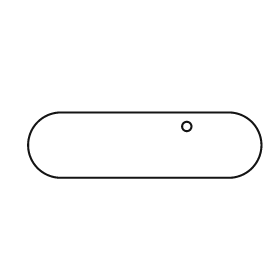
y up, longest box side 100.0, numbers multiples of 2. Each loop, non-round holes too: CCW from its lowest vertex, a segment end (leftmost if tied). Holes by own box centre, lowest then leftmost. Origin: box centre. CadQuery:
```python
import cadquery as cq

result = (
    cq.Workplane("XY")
    .moveTo(-36.0, -14.0)
    .lineTo(36.0, -14.0)
    .threePointArc((50.0, 0.0), (36.0, 14.0))
    .lineTo(-36.0, 14.0)
    .threePointArc((-50.0, 0.0), (-36.0, -14.0))
    .close()
    .moveTo(18.0, 8.0)
    .circle(2.0)
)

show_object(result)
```